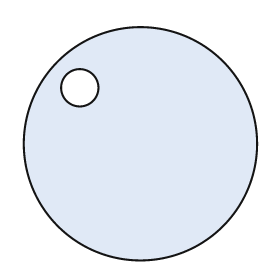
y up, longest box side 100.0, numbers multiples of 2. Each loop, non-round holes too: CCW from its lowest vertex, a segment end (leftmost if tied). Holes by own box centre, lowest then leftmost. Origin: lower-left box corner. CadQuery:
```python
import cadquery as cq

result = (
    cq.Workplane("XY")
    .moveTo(50.0, 50.0)
    .circle(50.0)
    .moveTo(24.0, 74.0)
    .circle(8.0)
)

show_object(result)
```